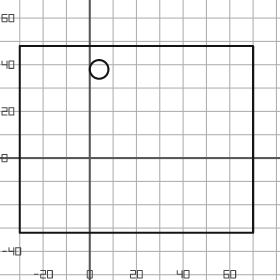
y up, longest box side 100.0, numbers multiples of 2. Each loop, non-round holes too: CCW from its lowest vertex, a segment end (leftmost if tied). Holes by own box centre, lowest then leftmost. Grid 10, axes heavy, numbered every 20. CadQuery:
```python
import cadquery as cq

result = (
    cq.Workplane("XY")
    .moveTo(-30.0, -32.0)
    .lineTo(70.0, -32.0)
    .lineTo(70.0, 48.0)
    .lineTo(-30.0, 48.0)
    .close()
    .moveTo(4.0, 38.0)
    .circle(4.0)
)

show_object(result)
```